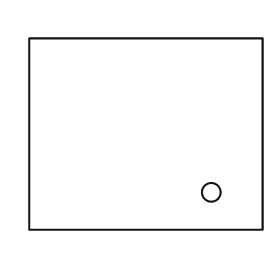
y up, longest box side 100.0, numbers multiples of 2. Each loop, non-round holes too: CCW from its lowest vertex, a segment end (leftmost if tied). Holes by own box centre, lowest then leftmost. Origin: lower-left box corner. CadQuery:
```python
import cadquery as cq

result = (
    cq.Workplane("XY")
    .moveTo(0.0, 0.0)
    .lineTo(100.0, 0.0)
    .lineTo(100.0, 82.0)
    .lineTo(0.0, 82.0)
    .close()
    .moveTo(78.0, 16.0)
    .circle(4.0)
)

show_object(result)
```